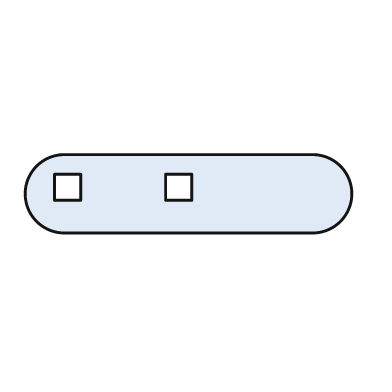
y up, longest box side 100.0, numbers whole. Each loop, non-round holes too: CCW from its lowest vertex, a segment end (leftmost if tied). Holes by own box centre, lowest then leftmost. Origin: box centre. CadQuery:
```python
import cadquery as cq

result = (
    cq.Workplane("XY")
    .moveTo(-38.0, -12.0)
    .lineTo(38.0, -12.0)
    .threePointArc((50.0, 0.0), (38.0, 12.0))
    .lineTo(-38.0, 12.0)
    .threePointArc((-50.0, 0.0), (-38.0, -12.0))
    .close()
    .moveTo(-41.0, -2.0)
    .lineTo(-33.0, -2.0)
    .lineTo(-33.0, 6.0)
    .lineTo(-41.0, 6.0)
    .close()
    .moveTo(-7.0, -2.0)
    .lineTo(1.0, -2.0)
    .lineTo(1.0, 6.0)
    .lineTo(-7.0, 6.0)
    .close()
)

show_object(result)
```